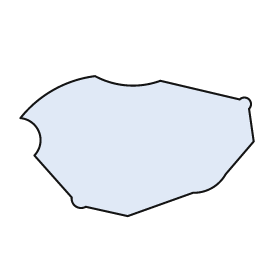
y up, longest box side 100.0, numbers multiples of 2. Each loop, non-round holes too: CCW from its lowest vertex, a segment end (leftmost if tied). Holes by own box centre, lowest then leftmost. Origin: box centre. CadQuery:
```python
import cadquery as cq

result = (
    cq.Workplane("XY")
    .moveTo(-4.0, -30.0)
    .lineTo(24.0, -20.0)
    .threePointArc((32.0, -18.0), (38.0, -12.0))
    .lineTo(50.0, 2.0)
    .lineTo(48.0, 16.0)
    .threePointArc((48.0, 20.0), (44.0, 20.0))
    .lineTo(10.0, 28.0)
    .threePointArc((-4.0, 26.0), (-18.0, 30.0))
    .threePointArc((-36.0, 24.0), (-50.0, 12.0))
    .threePointArc((-42.0, 6.0), (-44.0, -4.0))
    .lineTo(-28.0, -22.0)
    .threePointArc((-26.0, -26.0), (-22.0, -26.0))
    .close()
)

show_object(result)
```